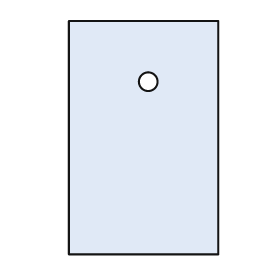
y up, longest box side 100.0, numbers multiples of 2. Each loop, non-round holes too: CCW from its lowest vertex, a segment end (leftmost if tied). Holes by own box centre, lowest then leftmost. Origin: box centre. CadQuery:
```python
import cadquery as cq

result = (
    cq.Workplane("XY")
    .moveTo(-32.0, -50.0)
    .lineTo(32.0, -50.0)
    .lineTo(32.0, 50.0)
    .lineTo(-32.0, 50.0)
    .close()
    .moveTo(2.0, 24.0)
    .circle(4.0)
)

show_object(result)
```